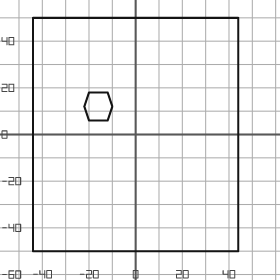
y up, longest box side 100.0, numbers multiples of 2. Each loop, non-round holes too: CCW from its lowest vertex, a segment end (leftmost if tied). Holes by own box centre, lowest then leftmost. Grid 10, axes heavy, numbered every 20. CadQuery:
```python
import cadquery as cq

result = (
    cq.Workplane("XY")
    .moveTo(-44.0, -50.0)
    .lineTo(44.0, -50.0)
    .lineTo(44.0, 50.0)
    .lineTo(-44.0, 50.0)
    .close()
    .moveTo(-20.0, 6.0)
    .lineTo(-12.0, 6.0)
    .lineTo(-10.0, 12.0)
    .lineTo(-12.0, 18.0)
    .lineTo(-20.0, 18.0)
    .lineTo(-22.0, 12.0)
    .close()
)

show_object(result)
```